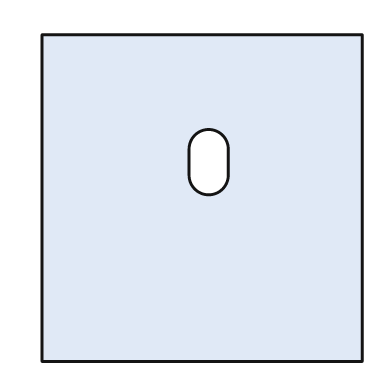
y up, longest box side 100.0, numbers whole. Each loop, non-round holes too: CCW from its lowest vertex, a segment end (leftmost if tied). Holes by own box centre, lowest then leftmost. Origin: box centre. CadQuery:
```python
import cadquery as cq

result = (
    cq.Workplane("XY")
    .moveTo(-49.0, -50.0)
    .lineTo(49.0, -50.0)
    .lineTo(49.0, 50.0)
    .lineTo(-49.0, 50.0)
    .close()
    .moveTo(-4.0, 7.0)
    .threePointArc((2.0, 1.0), (8.0, 7.0))
    .lineTo(8.0, 15.0)
    .threePointArc((2.0, 21.0), (-4.0, 15.0))
    .close()
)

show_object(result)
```